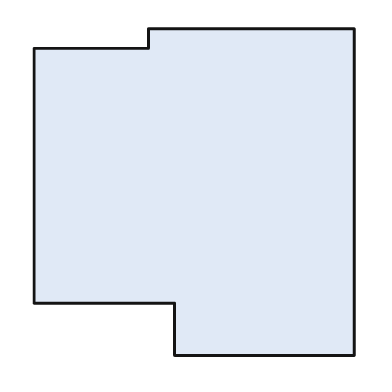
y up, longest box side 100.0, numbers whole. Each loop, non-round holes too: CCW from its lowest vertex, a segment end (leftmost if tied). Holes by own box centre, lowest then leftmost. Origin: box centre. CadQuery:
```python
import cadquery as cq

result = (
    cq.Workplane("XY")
    .moveTo(-6.0, -50.0)
    .lineTo(49.0, -50.0)
    .lineTo(49.0, 50.0)
    .lineTo(-14.0, 50.0)
    .lineTo(-14.0, 44.0)
    .lineTo(-49.0, 44.0)
    .lineTo(-49.0, -34.0)
    .lineTo(-6.0, -34.0)
    .close()
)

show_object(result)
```